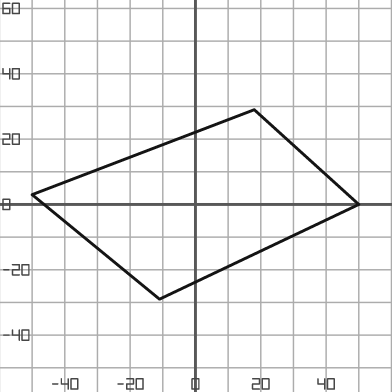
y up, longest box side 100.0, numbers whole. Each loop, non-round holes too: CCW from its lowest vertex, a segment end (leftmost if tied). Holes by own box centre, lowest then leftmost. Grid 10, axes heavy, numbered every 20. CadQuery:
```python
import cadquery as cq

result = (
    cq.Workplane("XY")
    .moveTo(-11.0, -29.0)
    .lineTo(50.0, 0.0)
    .lineTo(18.0, 29.0)
    .lineTo(-50.0, 3.0)
    .close()
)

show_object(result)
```